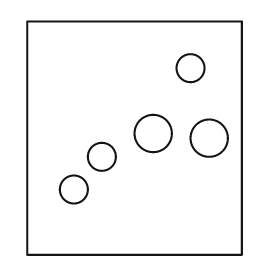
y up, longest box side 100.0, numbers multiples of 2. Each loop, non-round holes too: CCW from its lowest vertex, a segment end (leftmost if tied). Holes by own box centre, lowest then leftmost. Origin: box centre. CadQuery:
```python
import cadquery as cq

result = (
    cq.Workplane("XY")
    .moveTo(-46.0, -50.0)
    .lineTo(46.0, -50.0)
    .lineTo(46.0, 50.0)
    .lineTo(-46.0, 50.0)
    .close()
    .moveTo(-26.0, -22.0)
    .circle(6.0)
    .moveTo(-14.0, -8.0)
    .circle(6.0)
    .moveTo(32.0, 0.0)
    .circle(8.0)
    .moveTo(8.0, 2.0)
    .circle(8.0)
    .moveTo(24.0, 30.0)
    .circle(6.0)
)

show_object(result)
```